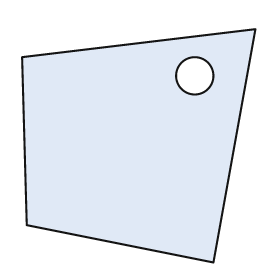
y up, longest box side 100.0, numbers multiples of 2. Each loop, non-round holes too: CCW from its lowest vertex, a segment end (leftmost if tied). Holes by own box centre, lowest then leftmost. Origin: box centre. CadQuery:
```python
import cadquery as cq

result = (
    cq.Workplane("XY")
    .moveTo(32.0, -50.0)
    .lineTo(50.0, 50.0)
    .lineTo(-50.0, 38.0)
    .lineTo(-48.0, -34.0)
    .close()
    .moveTo(24.0, 30.0)
    .circle(8.0)
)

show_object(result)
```